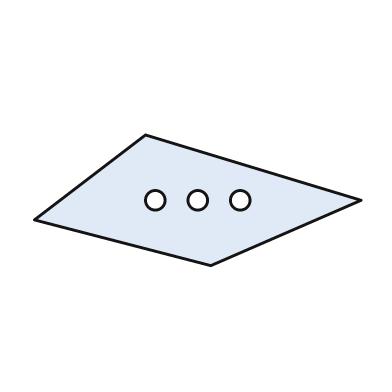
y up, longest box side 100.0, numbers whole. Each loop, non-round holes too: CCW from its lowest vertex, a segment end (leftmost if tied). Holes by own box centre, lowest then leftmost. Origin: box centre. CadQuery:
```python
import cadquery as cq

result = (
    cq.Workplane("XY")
    .moveTo(4.0, -20.0)
    .lineTo(50.0, 0.0)
    .lineTo(-16.0, 20.0)
    .lineTo(-50.0, -6.0)
    .close()
    .moveTo(-13.0, 0.0)
    .circle(3.0)
    .moveTo(0.0, 0.0)
    .circle(3.0)
    .moveTo(13.0, 0.0)
    .circle(3.0)
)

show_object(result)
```